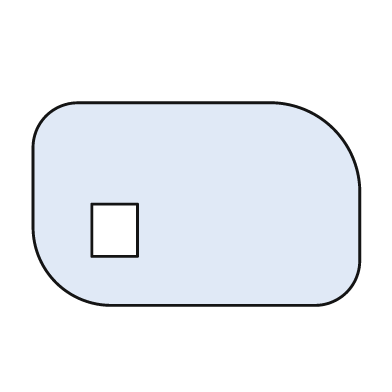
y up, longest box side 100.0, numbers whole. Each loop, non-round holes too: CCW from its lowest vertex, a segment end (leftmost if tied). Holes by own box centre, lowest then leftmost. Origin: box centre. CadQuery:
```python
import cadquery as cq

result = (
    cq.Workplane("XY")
    .moveTo(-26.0, -31.0)
    .lineTo(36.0, -31.0)
    .threePointArc((46.0, -27.0), (50.0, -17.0))
    .lineTo(50.0, 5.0)
    .threePointArc((42.0, 23.0), (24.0, 31.0))
    .lineTo(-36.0, 31.0)
    .threePointArc((-46.0, 27.0), (-50.0, 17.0))
    .lineTo(-50.0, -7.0)
    .threePointArc((-43.0, -24.0), (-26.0, -31.0))
    .close()
    .moveTo(-32.0, -16.0)
    .lineTo(-18.0, -16.0)
    .lineTo(-18.0, 0.0)
    .lineTo(-32.0, 0.0)
    .close()
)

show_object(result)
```